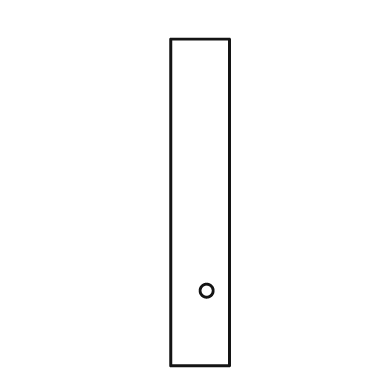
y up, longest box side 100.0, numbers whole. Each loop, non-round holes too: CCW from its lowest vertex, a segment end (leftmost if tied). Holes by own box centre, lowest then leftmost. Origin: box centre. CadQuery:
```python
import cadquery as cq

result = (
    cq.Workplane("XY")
    .moveTo(-9.0, -50.0)
    .lineTo(9.0, -50.0)
    .lineTo(9.0, 50.0)
    .lineTo(-9.0, 50.0)
    .close()
    .moveTo(2.0, -27.0)
    .circle(2.0)
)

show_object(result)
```